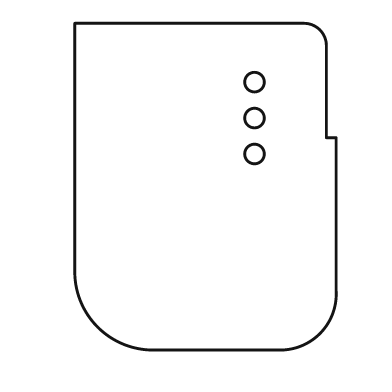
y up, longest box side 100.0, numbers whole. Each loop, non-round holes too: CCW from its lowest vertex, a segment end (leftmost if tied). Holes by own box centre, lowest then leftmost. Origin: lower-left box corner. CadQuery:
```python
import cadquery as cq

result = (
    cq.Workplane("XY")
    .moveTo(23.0, 0.0)
    .lineTo(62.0, 0.0)
    .threePointArc((75.0, 5.0), (80.0, 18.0))
    .lineTo(80.0, 65.0)
    .lineTo(77.0, 65.0)
    .lineTo(77.0, 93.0)
    .threePointArc((75.0, 98.0), (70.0, 100.0))
    .lineTo(0.0, 100.0)
    .lineTo(0.0, 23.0)
    .threePointArc((7.0, 7.0), (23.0, 0.0))
    .close()
    .moveTo(55.0, 60.0)
    .circle(3.0)
    .moveTo(55.0, 71.0)
    .circle(3.0)
    .moveTo(55.0, 82.0)
    .circle(3.0)
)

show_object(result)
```